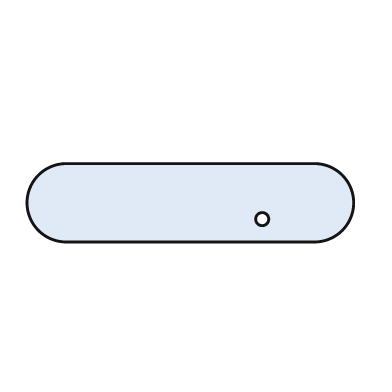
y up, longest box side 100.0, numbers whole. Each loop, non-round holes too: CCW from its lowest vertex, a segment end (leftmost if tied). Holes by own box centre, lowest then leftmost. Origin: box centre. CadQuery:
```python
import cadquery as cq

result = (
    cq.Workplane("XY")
    .moveTo(-38.0, -12.0)
    .lineTo(38.0, -12.0)
    .threePointArc((50.0, 0.0), (38.0, 12.0))
    .lineTo(-38.0, 12.0)
    .threePointArc((-50.0, 0.0), (-38.0, -12.0))
    .close()
    .moveTo(22.0, -5.0)
    .circle(2.0)
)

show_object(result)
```